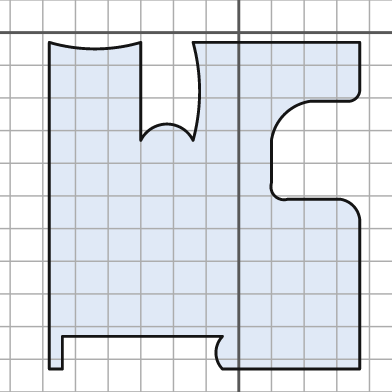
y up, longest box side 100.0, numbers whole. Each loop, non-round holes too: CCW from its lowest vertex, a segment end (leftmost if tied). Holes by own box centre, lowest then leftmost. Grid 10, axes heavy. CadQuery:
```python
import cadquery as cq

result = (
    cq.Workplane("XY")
    .moveTo(-58.0, -103.0)
    .lineTo(-54.0, -103.0)
    .lineTo(-54.0, -93.0)
    .lineTo(-5.0, -93.0)
    .threePointArc((-7.0, -98.0), (-5.0, -103.0))
    .lineTo(37.0, -103.0)
    .lineTo(37.0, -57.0)
    .threePointArc((35.0, -53.0), (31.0, -51.0))
    .lineTo(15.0, -51.0)
    .threePointArc((11.0, -50.0), (10.0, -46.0))
    .lineTo(10.0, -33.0)
    .threePointArc((14.0, -25.0), (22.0, -21.0))
    .lineTo(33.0, -21.0)
    .threePointArc((36.0, -20.0), (37.0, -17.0))
    .lineTo(37.0, -3.0)
    .lineTo(-14.0, -3.0)
    .threePointArc((-12.0, -18.0), (-14.0, -33.0))
    .threePointArc((-22.0, -28.0), (-30.0, -33.0))
    .lineTo(-30.0, -3.0)
    .threePointArc((-44.0, -5.0), (-58.0, -3.0))
    .close()
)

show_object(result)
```